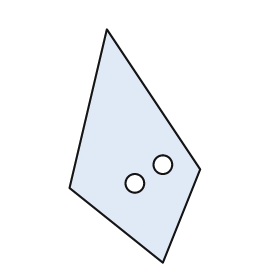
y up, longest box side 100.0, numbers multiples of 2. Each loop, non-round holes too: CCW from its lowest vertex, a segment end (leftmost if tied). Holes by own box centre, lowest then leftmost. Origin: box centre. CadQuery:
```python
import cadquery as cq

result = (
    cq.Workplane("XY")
    .moveTo(12.0, -50.0)
    .lineTo(28.0, -10.0)
    .lineTo(-12.0, 50.0)
    .lineTo(-28.0, -18.0)
    .close()
    .moveTo(0.0, -16.0)
    .circle(4.0)
    .moveTo(12.0, -8.0)
    .circle(4.0)
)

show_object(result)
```